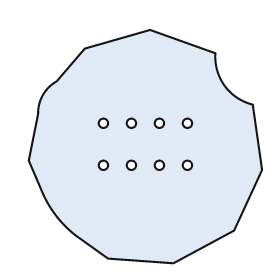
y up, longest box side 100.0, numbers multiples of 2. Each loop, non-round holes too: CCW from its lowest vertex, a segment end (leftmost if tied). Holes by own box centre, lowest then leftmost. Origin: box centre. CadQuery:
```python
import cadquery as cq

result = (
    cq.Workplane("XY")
    .moveTo(12.0, -50.0)
    .lineTo(38.0, -36.0)
    .lineTo(50.0, -10.0)
    .lineTo(46.0, 18.0)
    .threePointArc((34.0, 26.0), (30.0, 40.0))
    .lineTo(2.0, 50.0)
    .lineTo(-26.0, 42.0)
    .lineTo(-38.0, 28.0)
    .threePointArc((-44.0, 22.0), (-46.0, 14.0))
    .lineTo(-50.0, -6.0)
    .lineTo(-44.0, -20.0)
    .threePointArc((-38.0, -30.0), (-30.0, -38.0))
    .lineTo(-16.0, -48.0)
    .close()
    .moveTo(-18.0, -8.0)
    .circle(2.0)
    .moveTo(-6.0, -8.0)
    .circle(2.0)
    .moveTo(6.0, -8.0)
    .circle(2.0)
    .moveTo(18.0, -8.0)
    .circle(2.0)
    .moveTo(-18.0, 10.0)
    .circle(2.0)
    .moveTo(-6.0, 10.0)
    .circle(2.0)
    .moveTo(6.0, 10.0)
    .circle(2.0)
    .moveTo(18.0, 10.0)
    .circle(2.0)
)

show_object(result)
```